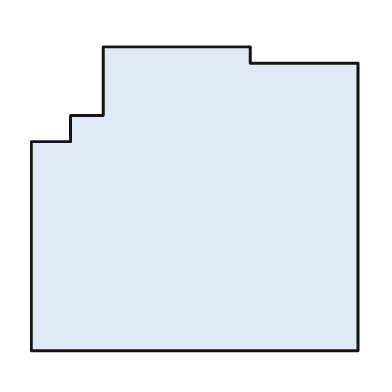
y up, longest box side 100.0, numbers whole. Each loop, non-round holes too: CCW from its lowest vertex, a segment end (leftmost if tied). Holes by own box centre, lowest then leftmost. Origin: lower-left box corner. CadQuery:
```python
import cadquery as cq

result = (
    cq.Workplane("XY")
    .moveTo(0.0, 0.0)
    .lineTo(100.0, 0.0)
    .lineTo(100.0, 88.0)
    .lineTo(67.0, 88.0)
    .lineTo(67.0, 93.0)
    .lineTo(22.0, 93.0)
    .lineTo(22.0, 72.0)
    .lineTo(12.0, 72.0)
    .lineTo(12.0, 64.0)
    .lineTo(0.0, 64.0)
    .close()
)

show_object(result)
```